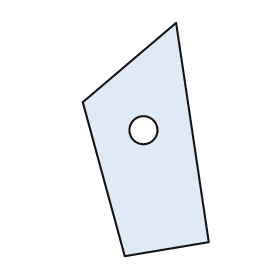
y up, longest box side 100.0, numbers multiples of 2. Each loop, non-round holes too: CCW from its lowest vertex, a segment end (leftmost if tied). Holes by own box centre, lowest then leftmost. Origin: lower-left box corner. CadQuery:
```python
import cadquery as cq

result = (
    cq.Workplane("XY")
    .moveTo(18.0, 0.0)
    .lineTo(54.0, 6.0)
    .lineTo(40.0, 100.0)
    .lineTo(0.0, 66.0)
    .close()
    .moveTo(26.0, 54.0)
    .circle(6.0)
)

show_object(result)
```